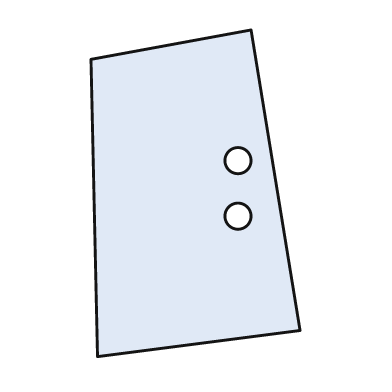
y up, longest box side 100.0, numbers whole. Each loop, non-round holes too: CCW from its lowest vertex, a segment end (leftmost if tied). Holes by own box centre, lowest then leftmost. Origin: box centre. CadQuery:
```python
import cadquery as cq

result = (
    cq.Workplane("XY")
    .moveTo(-30.0, -50.0)
    .lineTo(32.0, -42.0)
    .lineTo(17.0, 50.0)
    .lineTo(-32.0, 41.0)
    .close()
    .moveTo(13.0, -7.0)
    .circle(4.0)
    .moveTo(13.0, 10.0)
    .circle(4.0)
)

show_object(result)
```